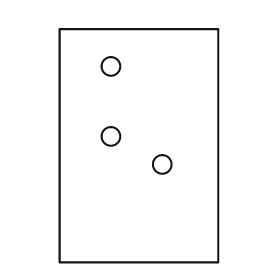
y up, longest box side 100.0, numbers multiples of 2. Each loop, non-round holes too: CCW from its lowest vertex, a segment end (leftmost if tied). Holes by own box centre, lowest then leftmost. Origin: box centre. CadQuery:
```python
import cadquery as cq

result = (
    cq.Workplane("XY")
    .moveTo(-34.0, -50.0)
    .lineTo(34.0, -50.0)
    .lineTo(34.0, 50.0)
    .lineTo(-34.0, 50.0)
    .close()
    .moveTo(10.0, -8.0)
    .circle(4.0)
    .moveTo(-12.0, 4.0)
    .circle(4.0)
    .moveTo(-12.0, 34.0)
    .circle(4.0)
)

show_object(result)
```